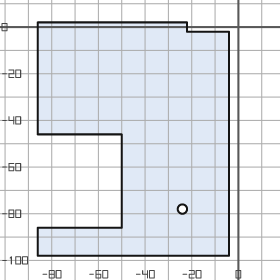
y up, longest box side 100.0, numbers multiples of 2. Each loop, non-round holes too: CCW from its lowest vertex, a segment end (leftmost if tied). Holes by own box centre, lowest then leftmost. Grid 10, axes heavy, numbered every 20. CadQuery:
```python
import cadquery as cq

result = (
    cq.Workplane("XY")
    .moveTo(-86.0, -98.0)
    .lineTo(-4.0, -98.0)
    .lineTo(-4.0, -2.0)
    .lineTo(-22.0, -2.0)
    .lineTo(-22.0, 2.0)
    .lineTo(-86.0, 2.0)
    .lineTo(-86.0, -46.0)
    .lineTo(-50.0, -46.0)
    .lineTo(-50.0, -86.0)
    .lineTo(-86.0, -86.0)
    .close()
    .moveTo(-24.0, -78.0)
    .circle(2.0)
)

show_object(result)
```